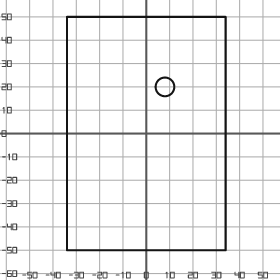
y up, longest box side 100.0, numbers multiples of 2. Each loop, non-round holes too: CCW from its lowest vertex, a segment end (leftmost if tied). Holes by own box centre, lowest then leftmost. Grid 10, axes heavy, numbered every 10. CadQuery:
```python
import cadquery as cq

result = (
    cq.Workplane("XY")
    .moveTo(-34.0, -50.0)
    .lineTo(34.0, -50.0)
    .lineTo(34.0, 50.0)
    .lineTo(-34.0, 50.0)
    .close()
    .moveTo(8.0, 20.0)
    .circle(4.0)
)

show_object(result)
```